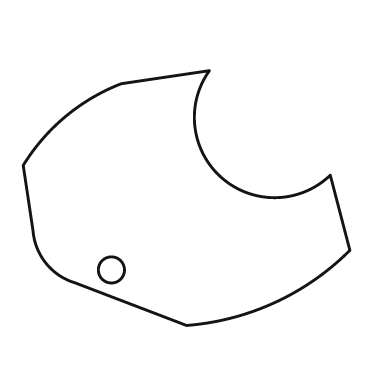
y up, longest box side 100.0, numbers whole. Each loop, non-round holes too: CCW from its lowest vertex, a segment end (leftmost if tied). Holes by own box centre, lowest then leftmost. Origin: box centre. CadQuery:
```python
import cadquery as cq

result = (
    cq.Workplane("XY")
    .moveTo(0.0, -39.0)
    .threePointArc((27.0, -32.0), (50.0, -16.0))
    .lineTo(44.0, 7.0)
    .threePointArc((11.0, 6.0), (7.0, 39.0))
    .lineTo(-20.0, 35.0)
    .threePointArc((-37.0, 25.0), (-50.0, 10.0))
    .lineTo(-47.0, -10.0)
    .threePointArc((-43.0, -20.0), (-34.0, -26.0))
    .close()
    .moveTo(-23.0, -22.0)
    .circle(4.0)
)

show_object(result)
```